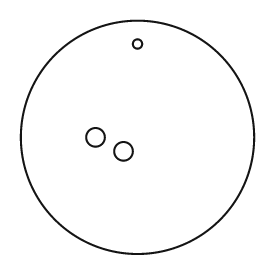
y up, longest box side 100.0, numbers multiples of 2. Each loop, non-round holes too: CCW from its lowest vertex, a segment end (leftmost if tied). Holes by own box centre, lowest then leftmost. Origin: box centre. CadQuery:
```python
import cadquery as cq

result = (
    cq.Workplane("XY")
    .moveTo(0.0, 0.0)
    .circle(50.0)
    .moveTo(-6.0, -6.0)
    .circle(4.0)
    .moveTo(-18.0, 0.0)
    .circle(4.0)
    .moveTo(0.0, 40.0)
    .circle(2.0)
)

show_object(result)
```